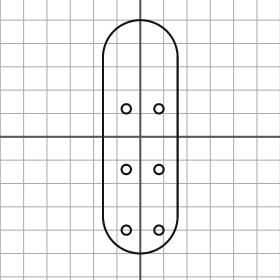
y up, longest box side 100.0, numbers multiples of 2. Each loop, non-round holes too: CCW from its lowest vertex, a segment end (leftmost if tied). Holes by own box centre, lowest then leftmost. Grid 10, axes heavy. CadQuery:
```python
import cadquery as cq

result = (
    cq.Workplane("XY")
    .moveTo(-16.0, -34.0)
    .threePointArc((0.0, -50.0), (16.0, -34.0))
    .lineTo(16.0, 34.0)
    .threePointArc((0.0, 50.0), (-16.0, 34.0))
    .close()
    .moveTo(-6.0, -40.0)
    .circle(2.0)
    .moveTo(8.0, -40.0)
    .circle(2.0)
    .moveTo(-6.0, -14.0)
    .circle(2.0)
    .moveTo(8.0, -14.0)
    .circle(2.0)
    .moveTo(-6.0, 12.0)
    .circle(2.0)
    .moveTo(8.0, 12.0)
    .circle(2.0)
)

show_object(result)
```